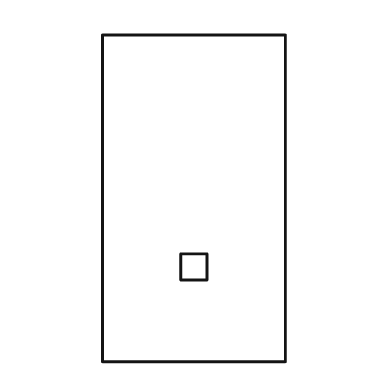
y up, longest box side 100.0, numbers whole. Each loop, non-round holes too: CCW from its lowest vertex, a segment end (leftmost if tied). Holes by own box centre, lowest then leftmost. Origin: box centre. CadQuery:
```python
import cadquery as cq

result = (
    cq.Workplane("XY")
    .moveTo(-28.0, -50.0)
    .lineTo(28.0, -50.0)
    .lineTo(28.0, 50.0)
    .lineTo(-28.0, 50.0)
    .close()
    .moveTo(-4.0, -25.0)
    .lineTo(4.0, -25.0)
    .lineTo(4.0, -17.0)
    .lineTo(-4.0, -17.0)
    .close()
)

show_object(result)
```